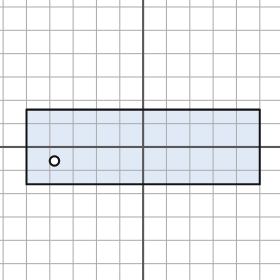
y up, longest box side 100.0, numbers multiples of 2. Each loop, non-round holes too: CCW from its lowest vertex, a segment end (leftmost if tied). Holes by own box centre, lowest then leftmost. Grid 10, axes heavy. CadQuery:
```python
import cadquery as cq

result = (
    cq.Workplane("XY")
    .moveTo(-50.0, -16.0)
    .lineTo(50.0, -16.0)
    .lineTo(50.0, 16.0)
    .lineTo(-50.0, 16.0)
    .close()
    .moveTo(-38.0, -6.0)
    .circle(2.0)
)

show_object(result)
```